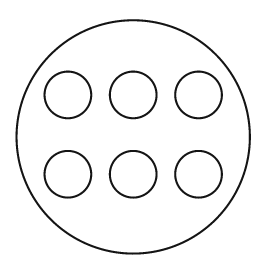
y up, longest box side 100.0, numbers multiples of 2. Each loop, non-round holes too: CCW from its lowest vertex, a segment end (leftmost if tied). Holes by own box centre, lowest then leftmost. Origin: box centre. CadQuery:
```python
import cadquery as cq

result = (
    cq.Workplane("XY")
    .moveTo(0.0, 0.0)
    .circle(50.0)
    .moveTo(-28.0, -16.0)
    .circle(10.0)
    .moveTo(0.0, -16.0)
    .circle(10.0)
    .moveTo(28.0, -16.0)
    .circle(10.0)
    .moveTo(-28.0, 18.0)
    .circle(10.0)
    .moveTo(0.0, 18.0)
    .circle(10.0)
    .moveTo(28.0, 18.0)
    .circle(10.0)
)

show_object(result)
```